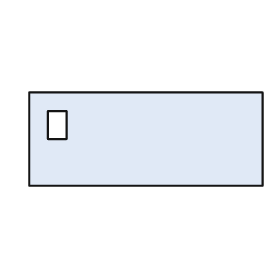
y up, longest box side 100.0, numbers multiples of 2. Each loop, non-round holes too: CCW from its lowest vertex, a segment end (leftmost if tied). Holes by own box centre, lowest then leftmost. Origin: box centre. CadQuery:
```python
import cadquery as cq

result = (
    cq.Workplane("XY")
    .moveTo(-50.0, -20.0)
    .lineTo(50.0, -20.0)
    .lineTo(50.0, 20.0)
    .lineTo(-50.0, 20.0)
    .close()
    .moveTo(-42.0, 0.0)
    .lineTo(-34.0, 0.0)
    .lineTo(-34.0, 12.0)
    .lineTo(-42.0, 12.0)
    .close()
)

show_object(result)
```